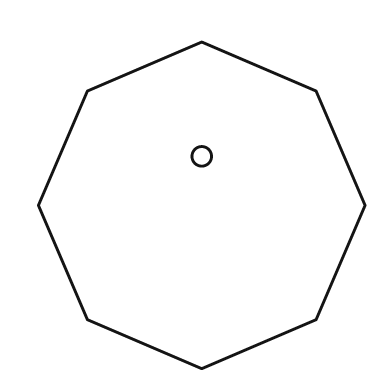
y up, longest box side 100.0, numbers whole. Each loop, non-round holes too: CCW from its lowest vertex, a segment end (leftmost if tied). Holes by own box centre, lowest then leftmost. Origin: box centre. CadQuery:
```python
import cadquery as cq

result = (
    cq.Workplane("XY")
    .moveTo(0.0, -50.0)
    .lineTo(35.0, -35.0)
    .lineTo(50.0, 0.0)
    .lineTo(35.0, 35.0)
    .lineTo(0.0, 50.0)
    .lineTo(-35.0, 35.0)
    .lineTo(-50.0, 0.0)
    .lineTo(-35.0, -35.0)
    .close()
    .moveTo(0.0, 15.0)
    .circle(3.0)
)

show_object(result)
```